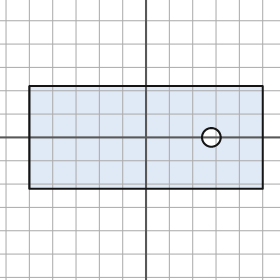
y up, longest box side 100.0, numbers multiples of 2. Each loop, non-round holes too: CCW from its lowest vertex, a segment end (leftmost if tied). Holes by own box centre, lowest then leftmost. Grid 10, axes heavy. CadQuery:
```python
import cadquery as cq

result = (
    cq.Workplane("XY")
    .moveTo(-50.0, -22.0)
    .lineTo(50.0, -22.0)
    .lineTo(50.0, 22.0)
    .lineTo(-50.0, 22.0)
    .close()
    .moveTo(28.0, 0.0)
    .circle(4.0)
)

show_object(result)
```